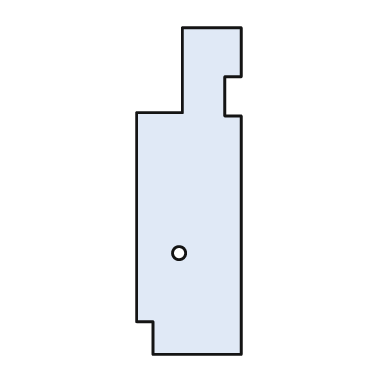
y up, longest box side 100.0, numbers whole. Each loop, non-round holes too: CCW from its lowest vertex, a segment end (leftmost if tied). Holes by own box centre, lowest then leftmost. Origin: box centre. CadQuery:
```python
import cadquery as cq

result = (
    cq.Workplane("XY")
    .moveTo(-11.0, -50.0)
    .lineTo(16.0, -50.0)
    .lineTo(16.0, 23.0)
    .lineTo(11.0, 23.0)
    .lineTo(11.0, 35.0)
    .lineTo(16.0, 35.0)
    .lineTo(16.0, 50.0)
    .lineTo(-2.0, 50.0)
    .lineTo(-2.0, 24.0)
    .lineTo(-16.0, 24.0)
    .lineTo(-16.0, -40.0)
    .lineTo(-11.0, -40.0)
    .close()
    .moveTo(-3.0, -19.0)
    .circle(2.0)
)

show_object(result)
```